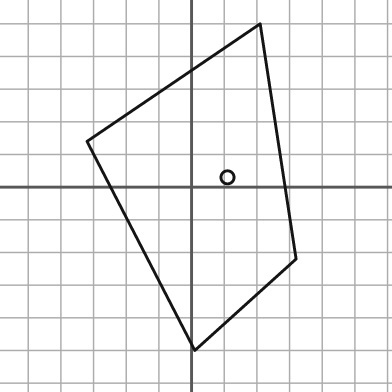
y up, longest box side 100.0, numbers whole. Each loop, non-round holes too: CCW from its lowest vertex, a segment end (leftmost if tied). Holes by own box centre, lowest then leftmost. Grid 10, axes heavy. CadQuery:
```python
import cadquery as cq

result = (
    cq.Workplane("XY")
    .moveTo(1.0, -50.0)
    .lineTo(32.0, -22.0)
    .lineTo(21.0, 50.0)
    .lineTo(-32.0, 14.0)
    .close()
    .moveTo(11.0, 3.0)
    .circle(2.0)
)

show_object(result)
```